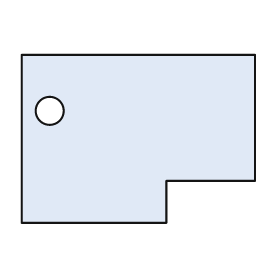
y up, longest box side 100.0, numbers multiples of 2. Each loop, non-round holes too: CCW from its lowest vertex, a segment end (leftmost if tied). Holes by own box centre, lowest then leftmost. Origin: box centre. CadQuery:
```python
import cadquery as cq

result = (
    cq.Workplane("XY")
    .moveTo(-50.0, -36.0)
    .lineTo(12.0, -36.0)
    .lineTo(12.0, -18.0)
    .lineTo(50.0, -18.0)
    .lineTo(50.0, 36.0)
    .lineTo(-50.0, 36.0)
    .close()
    .moveTo(-38.0, 12.0)
    .circle(6.0)
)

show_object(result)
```